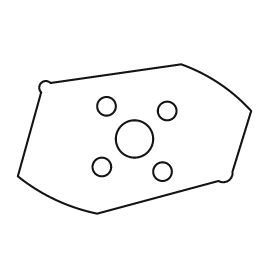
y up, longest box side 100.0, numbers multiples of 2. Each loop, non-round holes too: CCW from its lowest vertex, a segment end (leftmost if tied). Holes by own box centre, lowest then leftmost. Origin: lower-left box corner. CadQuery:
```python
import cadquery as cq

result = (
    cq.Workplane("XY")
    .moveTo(34.0, 0.0)
    .lineTo(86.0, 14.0)
    .threePointArc((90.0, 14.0), (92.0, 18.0))
    .lineTo(100.0, 44.0)
    .threePointArc((86.0, 56.0), (70.0, 64.0))
    .lineTo(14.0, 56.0)
    .threePointArc((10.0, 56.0), (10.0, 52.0))
    .lineTo(0.0, 16.0)
    .threePointArc((16.0, 6.0), (34.0, 0.0))
    .close()
    .moveTo(62.0, 18.0)
    .circle(4.0)
    .moveTo(36.0, 20.0)
    .circle(4.0)
    .moveTo(50.0, 32.0)
    .circle(8.0)
    .moveTo(64.0, 44.0)
    .circle(4.0)
    .moveTo(38.0, 46.0)
    .circle(4.0)
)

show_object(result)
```